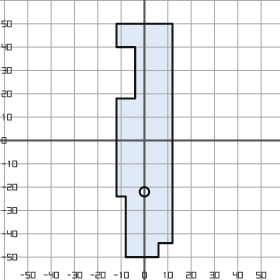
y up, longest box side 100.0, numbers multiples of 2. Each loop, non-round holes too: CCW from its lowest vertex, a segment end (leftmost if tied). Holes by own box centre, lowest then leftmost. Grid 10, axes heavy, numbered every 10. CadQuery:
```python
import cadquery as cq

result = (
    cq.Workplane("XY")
    .moveTo(-8.0, -50.0)
    .lineTo(6.0, -50.0)
    .lineTo(6.0, -44.0)
    .lineTo(12.0, -44.0)
    .lineTo(12.0, 50.0)
    .lineTo(-12.0, 50.0)
    .lineTo(-12.0, 40.0)
    .lineTo(-4.0, 40.0)
    .lineTo(-4.0, 18.0)
    .lineTo(-12.0, 18.0)
    .lineTo(-12.0, -24.0)
    .lineTo(-8.0, -24.0)
    .close()
    .moveTo(0.0, -22.0)
    .circle(2.0)
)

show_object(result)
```